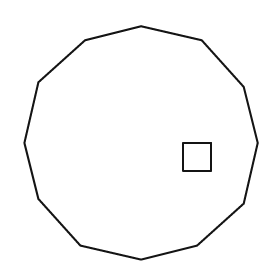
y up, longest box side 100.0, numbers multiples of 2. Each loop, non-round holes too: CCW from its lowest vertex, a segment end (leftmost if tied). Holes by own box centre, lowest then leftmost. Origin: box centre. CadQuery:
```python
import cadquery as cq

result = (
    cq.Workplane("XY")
    .moveTo(0.0, -50.0)
    .lineTo(24.0, -44.0)
    .lineTo(44.0, -26.0)
    .lineTo(50.0, 0.0)
    .lineTo(44.0, 24.0)
    .lineTo(26.0, 44.0)
    .lineTo(0.0, 50.0)
    .lineTo(-24.0, 44.0)
    .lineTo(-44.0, 26.0)
    .lineTo(-50.0, 0.0)
    .lineTo(-44.0, -24.0)
    .lineTo(-26.0, -44.0)
    .close()
    .moveTo(18.0, -12.0)
    .lineTo(30.0, -12.0)
    .lineTo(30.0, 0.0)
    .lineTo(18.0, 0.0)
    .close()
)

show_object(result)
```